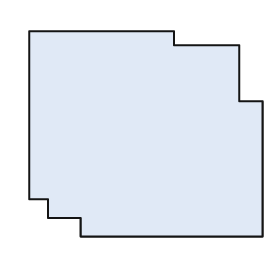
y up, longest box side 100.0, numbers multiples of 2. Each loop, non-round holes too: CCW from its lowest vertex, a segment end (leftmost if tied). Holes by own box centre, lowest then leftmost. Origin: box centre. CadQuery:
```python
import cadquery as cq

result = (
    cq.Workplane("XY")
    .moveTo(-28.0, -44.0)
    .lineTo(50.0, -44.0)
    .lineTo(50.0, 14.0)
    .lineTo(40.0, 14.0)
    .lineTo(40.0, 38.0)
    .lineTo(12.0, 38.0)
    .lineTo(12.0, 44.0)
    .lineTo(-50.0, 44.0)
    .lineTo(-50.0, -28.0)
    .lineTo(-42.0, -28.0)
    .lineTo(-42.0, -36.0)
    .lineTo(-28.0, -36.0)
    .close()
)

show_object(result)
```